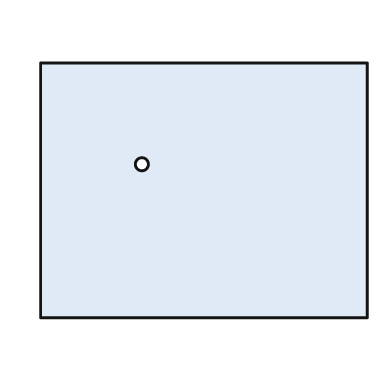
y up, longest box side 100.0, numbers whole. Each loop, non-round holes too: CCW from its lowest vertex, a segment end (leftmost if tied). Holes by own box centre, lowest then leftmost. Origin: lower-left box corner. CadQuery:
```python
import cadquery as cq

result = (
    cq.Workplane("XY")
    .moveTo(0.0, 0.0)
    .lineTo(100.0, 0.0)
    .lineTo(100.0, 78.0)
    .lineTo(0.0, 78.0)
    .close()
    .moveTo(31.0, 47.0)
    .circle(2.0)
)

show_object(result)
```